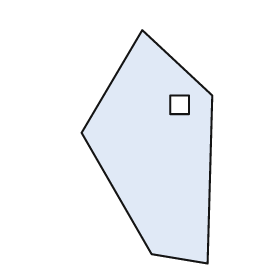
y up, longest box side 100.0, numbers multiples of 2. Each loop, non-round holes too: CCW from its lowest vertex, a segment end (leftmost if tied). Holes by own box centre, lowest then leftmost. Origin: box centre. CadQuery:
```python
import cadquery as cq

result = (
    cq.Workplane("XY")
    .moveTo(26.0, -50.0)
    .lineTo(28.0, 22.0)
    .lineTo(-2.0, 50.0)
    .lineTo(-28.0, 6.0)
    .lineTo(2.0, -46.0)
    .close()
    .moveTo(10.0, 14.0)
    .lineTo(18.0, 14.0)
    .lineTo(18.0, 22.0)
    .lineTo(10.0, 22.0)
    .close()
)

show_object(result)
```